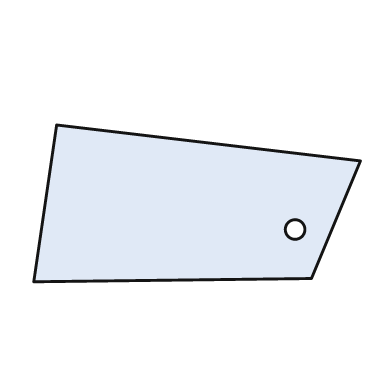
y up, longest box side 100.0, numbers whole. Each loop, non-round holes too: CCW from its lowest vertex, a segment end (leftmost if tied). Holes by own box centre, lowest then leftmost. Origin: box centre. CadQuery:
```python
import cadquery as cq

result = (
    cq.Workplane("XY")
    .moveTo(-50.0, -24.0)
    .lineTo(35.0, -23.0)
    .lineTo(50.0, 13.0)
    .lineTo(-43.0, 24.0)
    .close()
    .moveTo(30.0, -8.0)
    .circle(3.0)
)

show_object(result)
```